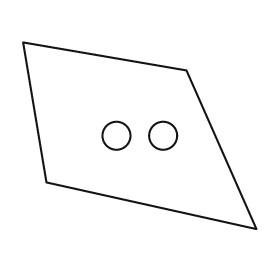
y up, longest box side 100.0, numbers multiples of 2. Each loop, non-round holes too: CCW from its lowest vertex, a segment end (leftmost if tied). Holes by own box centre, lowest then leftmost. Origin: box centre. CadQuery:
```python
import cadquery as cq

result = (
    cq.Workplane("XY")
    .moveTo(50.0, -40.0)
    .lineTo(20.0, 28.0)
    .lineTo(-50.0, 40.0)
    .lineTo(-40.0, -20.0)
    .close()
    .moveTo(-10.0, 0.0)
    .circle(6.0)
    .moveTo(10.0, 0.0)
    .circle(6.0)
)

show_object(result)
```